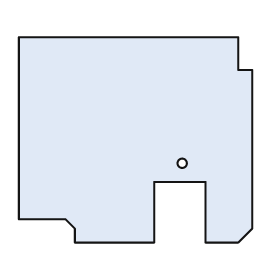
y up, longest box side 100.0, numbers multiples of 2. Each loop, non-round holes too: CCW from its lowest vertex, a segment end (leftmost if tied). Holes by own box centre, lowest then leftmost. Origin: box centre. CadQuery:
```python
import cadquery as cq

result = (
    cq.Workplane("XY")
    .moveTo(-26.0, -44.0)
    .lineTo(8.0, -44.0)
    .lineTo(8.0, -18.0)
    .lineTo(30.0, -18.0)
    .lineTo(30.0, -44.0)
    .lineTo(44.0, -44.0)
    .lineTo(50.0, -38.0)
    .lineTo(50.0, 30.0)
    .lineTo(44.0, 30.0)
    .lineTo(44.0, 44.0)
    .lineTo(-50.0, 44.0)
    .lineTo(-50.0, -34.0)
    .lineTo(-30.0, -34.0)
    .lineTo(-26.0, -38.0)
    .close()
    .moveTo(20.0, -10.0)
    .circle(2.0)
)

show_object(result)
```